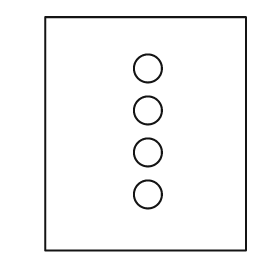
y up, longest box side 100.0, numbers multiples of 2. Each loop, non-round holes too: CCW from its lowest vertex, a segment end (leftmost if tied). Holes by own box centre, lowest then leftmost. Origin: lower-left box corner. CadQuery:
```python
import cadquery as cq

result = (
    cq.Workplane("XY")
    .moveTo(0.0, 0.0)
    .lineTo(86.0, 0.0)
    .lineTo(86.0, 100.0)
    .lineTo(0.0, 100.0)
    .close()
    .moveTo(44.0, 24.0)
    .circle(6.0)
    .moveTo(44.0, 42.0)
    .circle(6.0)
    .moveTo(44.0, 60.0)
    .circle(6.0)
    .moveTo(44.0, 78.0)
    .circle(6.0)
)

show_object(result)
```